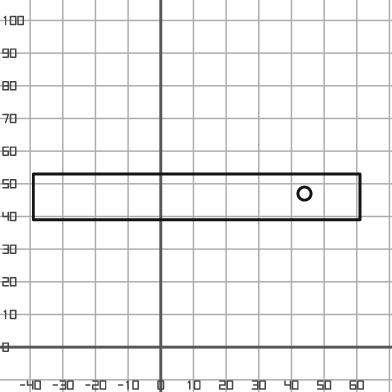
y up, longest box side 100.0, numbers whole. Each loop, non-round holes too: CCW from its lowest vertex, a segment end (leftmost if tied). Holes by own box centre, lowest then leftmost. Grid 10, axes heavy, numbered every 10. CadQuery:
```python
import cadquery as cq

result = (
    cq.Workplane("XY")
    .moveTo(-39.0, 39.0)
    .lineTo(61.0, 39.0)
    .lineTo(61.0, 53.0)
    .lineTo(-39.0, 53.0)
    .close()
    .moveTo(44.0, 47.0)
    .circle(2.0)
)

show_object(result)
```